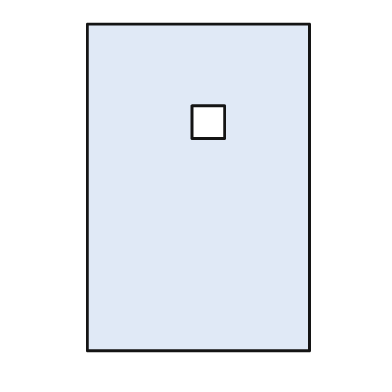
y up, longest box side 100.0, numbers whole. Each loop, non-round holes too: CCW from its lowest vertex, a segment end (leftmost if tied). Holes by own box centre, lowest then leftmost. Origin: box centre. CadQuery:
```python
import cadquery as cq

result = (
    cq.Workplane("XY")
    .moveTo(-34.0, -50.0)
    .lineTo(34.0, -50.0)
    .lineTo(34.0, 50.0)
    .lineTo(-34.0, 50.0)
    .close()
    .moveTo(-2.0, 15.0)
    .lineTo(8.0, 15.0)
    .lineTo(8.0, 25.0)
    .lineTo(-2.0, 25.0)
    .close()
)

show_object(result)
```